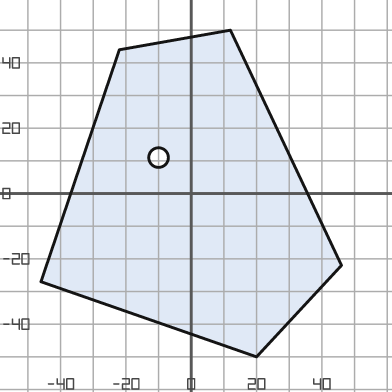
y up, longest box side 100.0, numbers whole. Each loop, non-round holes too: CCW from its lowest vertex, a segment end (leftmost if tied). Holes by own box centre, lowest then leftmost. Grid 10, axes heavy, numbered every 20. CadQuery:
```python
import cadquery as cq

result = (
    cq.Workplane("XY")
    .moveTo(20.0, -50.0)
    .lineTo(46.0, -22.0)
    .lineTo(12.0, 50.0)
    .lineTo(-22.0, 44.0)
    .lineTo(-46.0, -27.0)
    .close()
    .moveTo(-10.0, 11.0)
    .circle(3.0)
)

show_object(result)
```